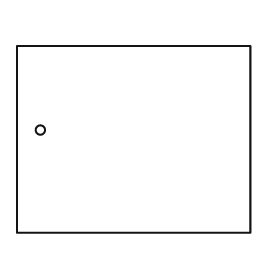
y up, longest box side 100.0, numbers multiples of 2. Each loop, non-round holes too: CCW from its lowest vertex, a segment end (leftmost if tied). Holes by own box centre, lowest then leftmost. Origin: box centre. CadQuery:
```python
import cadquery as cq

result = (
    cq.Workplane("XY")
    .moveTo(-50.0, -40.0)
    .lineTo(50.0, -40.0)
    .lineTo(50.0, 40.0)
    .lineTo(-50.0, 40.0)
    .close()
    .moveTo(-40.0, 4.0)
    .circle(2.0)
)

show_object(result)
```